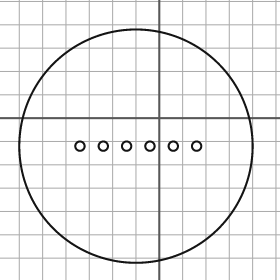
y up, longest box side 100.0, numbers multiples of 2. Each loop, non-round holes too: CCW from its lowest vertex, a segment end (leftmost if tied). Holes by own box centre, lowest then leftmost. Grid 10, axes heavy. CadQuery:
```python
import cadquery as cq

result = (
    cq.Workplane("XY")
    .moveTo(-10.0, -12.0)
    .circle(50.0)
    .moveTo(-34.0, -12.0)
    .circle(2.0)
    .moveTo(-24.0, -12.0)
    .circle(2.0)
    .moveTo(-14.0, -12.0)
    .circle(2.0)
    .moveTo(-4.0, -12.0)
    .circle(2.0)
    .moveTo(6.0, -12.0)
    .circle(2.0)
    .moveTo(16.0, -12.0)
    .circle(2.0)
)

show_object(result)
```